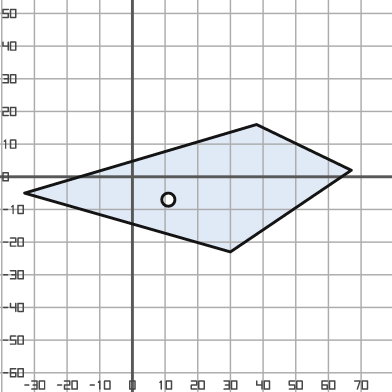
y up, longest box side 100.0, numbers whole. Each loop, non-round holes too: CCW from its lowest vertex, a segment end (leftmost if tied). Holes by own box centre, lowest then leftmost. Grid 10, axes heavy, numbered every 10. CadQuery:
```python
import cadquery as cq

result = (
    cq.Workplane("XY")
    .moveTo(30.0, -23.0)
    .lineTo(67.0, 2.0)
    .lineTo(38.0, 16.0)
    .lineTo(-33.0, -5.0)
    .close()
    .moveTo(11.0, -7.0)
    .circle(2.0)
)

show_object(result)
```